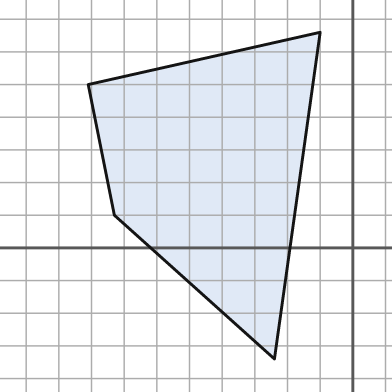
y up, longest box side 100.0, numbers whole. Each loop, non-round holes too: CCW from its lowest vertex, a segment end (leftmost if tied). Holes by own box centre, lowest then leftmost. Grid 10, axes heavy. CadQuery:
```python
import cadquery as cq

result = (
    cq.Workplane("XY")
    .moveTo(-24.0, -34.0)
    .lineTo(-10.0, 66.0)
    .lineTo(-81.0, 50.0)
    .lineTo(-73.0, 10.0)
    .close()
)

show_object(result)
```